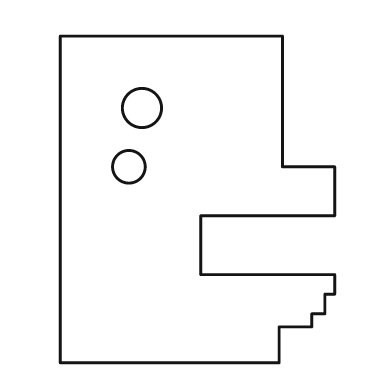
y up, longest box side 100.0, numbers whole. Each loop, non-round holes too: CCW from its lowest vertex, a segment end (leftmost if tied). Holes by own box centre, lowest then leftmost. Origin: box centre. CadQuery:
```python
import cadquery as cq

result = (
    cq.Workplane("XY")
    .moveTo(-42.0, -50.0)
    .lineTo(25.0, -50.0)
    .lineTo(25.0, -39.0)
    .lineTo(35.0, -39.0)
    .lineTo(35.0, -35.0)
    .lineTo(39.0, -35.0)
    .lineTo(39.0, -29.0)
    .lineTo(42.0, -29.0)
    .lineTo(42.0, -23.0)
    .lineTo(1.0, -23.0)
    .lineTo(1.0, -5.0)
    .lineTo(42.0, -5.0)
    .lineTo(42.0, 10.0)
    .lineTo(26.0, 10.0)
    .lineTo(26.0, 50.0)
    .lineTo(-42.0, 50.0)
    .close()
    .moveTo(-21.0, 10.0)
    .circle(5.0)
    .moveTo(-17.0, 28.0)
    .circle(6.0)
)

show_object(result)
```